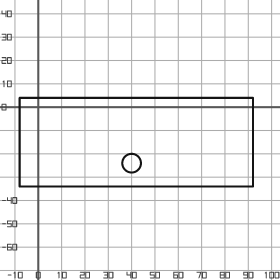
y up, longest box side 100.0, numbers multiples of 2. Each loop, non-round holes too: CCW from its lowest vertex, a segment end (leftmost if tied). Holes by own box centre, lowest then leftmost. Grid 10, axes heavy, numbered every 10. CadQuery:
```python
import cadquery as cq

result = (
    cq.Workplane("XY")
    .moveTo(-8.0, -34.0)
    .lineTo(92.0, -34.0)
    .lineTo(92.0, 4.0)
    .lineTo(-8.0, 4.0)
    .close()
    .moveTo(40.0, -24.0)
    .circle(4.0)
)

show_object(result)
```